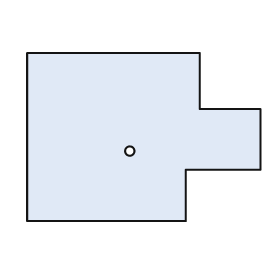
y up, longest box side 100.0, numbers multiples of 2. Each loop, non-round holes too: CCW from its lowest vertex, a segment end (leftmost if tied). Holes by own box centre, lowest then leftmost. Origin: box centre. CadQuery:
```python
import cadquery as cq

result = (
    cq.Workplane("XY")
    .moveTo(-50.0, -36.0)
    .lineTo(18.0, -36.0)
    .lineTo(18.0, -14.0)
    .lineTo(50.0, -14.0)
    .lineTo(50.0, 12.0)
    .lineTo(24.0, 12.0)
    .lineTo(24.0, 36.0)
    .lineTo(-50.0, 36.0)
    .close()
    .moveTo(-6.0, -6.0)
    .circle(2.0)
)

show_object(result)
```